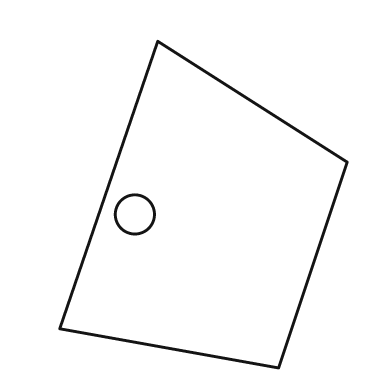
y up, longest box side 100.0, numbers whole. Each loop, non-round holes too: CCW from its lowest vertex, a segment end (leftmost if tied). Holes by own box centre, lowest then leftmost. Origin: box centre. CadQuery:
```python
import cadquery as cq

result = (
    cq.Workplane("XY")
    .moveTo(23.0, -50.0)
    .lineTo(44.0, 13.0)
    .lineTo(-14.0, 50.0)
    .lineTo(-44.0, -38.0)
    .close()
    .moveTo(-21.0, -3.0)
    .circle(6.0)
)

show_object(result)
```